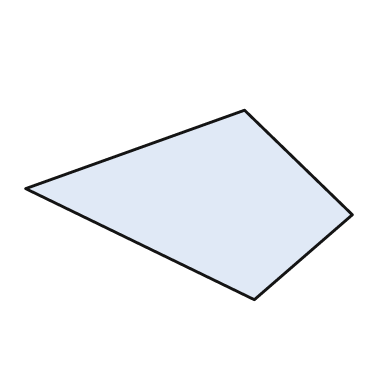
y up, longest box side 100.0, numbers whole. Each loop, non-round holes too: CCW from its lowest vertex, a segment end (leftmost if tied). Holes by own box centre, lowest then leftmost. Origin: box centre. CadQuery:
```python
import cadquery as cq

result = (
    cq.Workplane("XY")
    .moveTo(20.0, -29.0)
    .lineTo(50.0, -3.0)
    .lineTo(17.0, 29.0)
    .lineTo(-50.0, 5.0)
    .close()
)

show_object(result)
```